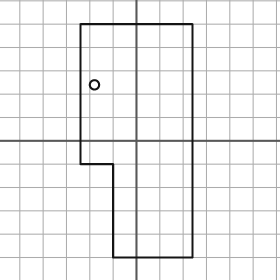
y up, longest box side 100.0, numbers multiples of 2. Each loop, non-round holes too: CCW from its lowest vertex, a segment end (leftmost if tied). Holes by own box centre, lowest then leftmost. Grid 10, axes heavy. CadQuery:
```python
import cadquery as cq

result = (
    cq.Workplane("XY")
    .moveTo(-10.0, -50.0)
    .lineTo(24.0, -50.0)
    .lineTo(24.0, 50.0)
    .lineTo(-24.0, 50.0)
    .lineTo(-24.0, -10.0)
    .lineTo(-10.0, -10.0)
    .close()
    .moveTo(-18.0, 24.0)
    .circle(2.0)
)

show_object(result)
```